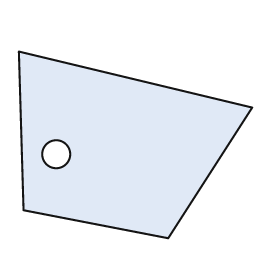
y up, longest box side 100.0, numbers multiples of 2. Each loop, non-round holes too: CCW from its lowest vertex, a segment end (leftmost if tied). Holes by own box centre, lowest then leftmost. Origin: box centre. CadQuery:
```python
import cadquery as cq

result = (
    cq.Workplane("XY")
    .moveTo(14.0, -40.0)
    .lineTo(50.0, 16.0)
    .lineTo(-50.0, 40.0)
    .lineTo(-48.0, -28.0)
    .close()
    .moveTo(-34.0, -4.0)
    .circle(6.0)
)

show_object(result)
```